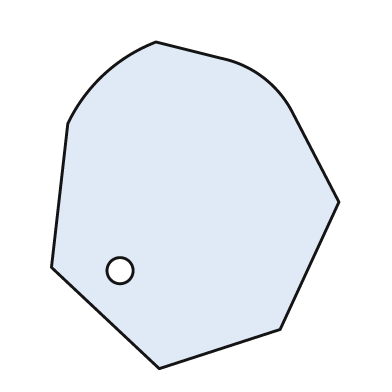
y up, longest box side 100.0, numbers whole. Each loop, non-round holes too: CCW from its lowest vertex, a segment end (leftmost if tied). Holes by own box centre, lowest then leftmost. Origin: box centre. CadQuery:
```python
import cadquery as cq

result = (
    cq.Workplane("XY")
    .moveTo(-11.0, -50.0)
    .lineTo(26.0, -38.0)
    .lineTo(44.0, 1.0)
    .lineTo(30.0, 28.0)
    .threePointArc((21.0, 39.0), (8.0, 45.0))
    .lineTo(-12.0, 50.0)
    .threePointArc((-28.0, 40.0), (-39.0, 25.0))
    .lineTo(-44.0, -19.0)
    .close()
    .moveTo(-23.0, -20.0)
    .circle(4.0)
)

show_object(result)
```